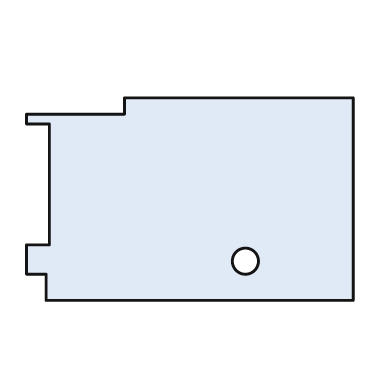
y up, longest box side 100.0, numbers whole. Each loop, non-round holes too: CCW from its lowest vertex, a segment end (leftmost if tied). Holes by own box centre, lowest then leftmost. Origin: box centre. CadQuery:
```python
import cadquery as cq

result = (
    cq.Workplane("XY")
    .moveTo(-44.0, -31.0)
    .lineTo(50.0, -31.0)
    .lineTo(50.0, 31.0)
    .lineTo(-20.0, 31.0)
    .lineTo(-20.0, 26.0)
    .lineTo(-50.0, 26.0)
    .lineTo(-50.0, 23.0)
    .lineTo(-43.0, 23.0)
    .lineTo(-43.0, -14.0)
    .lineTo(-50.0, -14.0)
    .lineTo(-50.0, -23.0)
    .lineTo(-44.0, -23.0)
    .close()
    .moveTo(17.0, -19.0)
    .circle(4.0)
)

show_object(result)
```